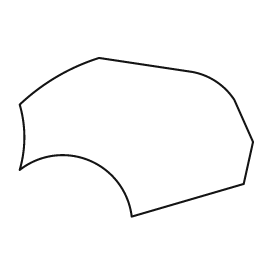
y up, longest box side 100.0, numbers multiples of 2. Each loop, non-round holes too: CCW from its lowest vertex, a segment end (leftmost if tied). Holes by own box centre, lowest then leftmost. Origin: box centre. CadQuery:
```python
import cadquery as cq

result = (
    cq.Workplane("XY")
    .moveTo(-2.0, -34.0)
    .lineTo(46.0, -20.0)
    .lineTo(50.0, -2.0)
    .lineTo(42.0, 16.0)
    .threePointArc((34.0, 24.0), (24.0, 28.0))
    .lineTo(-16.0, 34.0)
    .threePointArc((-34.0, 26.0), (-50.0, 14.0))
    .threePointArc((-48.0, 0.0), (-50.0, -14.0))
    .threePointArc((-20.0, -10.0), (-2.0, -34.0))
    .close()
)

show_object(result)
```